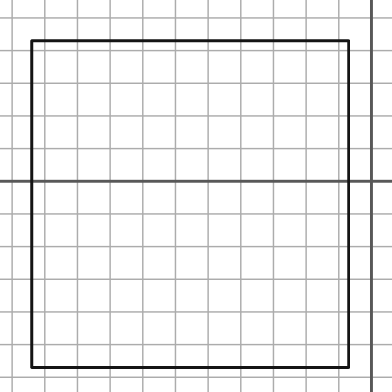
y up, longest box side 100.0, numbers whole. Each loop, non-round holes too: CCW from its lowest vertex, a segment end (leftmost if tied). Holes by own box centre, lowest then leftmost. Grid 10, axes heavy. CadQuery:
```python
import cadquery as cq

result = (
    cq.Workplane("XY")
    .moveTo(-104.0, -57.0)
    .lineTo(-7.0, -57.0)
    .lineTo(-7.0, 43.0)
    .lineTo(-104.0, 43.0)
    .close()
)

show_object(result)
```